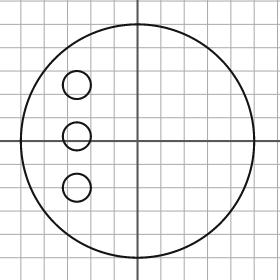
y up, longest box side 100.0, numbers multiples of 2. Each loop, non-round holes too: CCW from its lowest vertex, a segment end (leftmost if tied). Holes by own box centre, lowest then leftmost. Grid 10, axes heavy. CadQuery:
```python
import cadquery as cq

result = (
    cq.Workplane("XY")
    .moveTo(0.0, 0.0)
    .circle(50.0)
    .moveTo(-26.0, -20.0)
    .circle(6.0)
    .moveTo(-26.0, 2.0)
    .circle(6.0)
    .moveTo(-26.0, 24.0)
    .circle(6.0)
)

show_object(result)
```